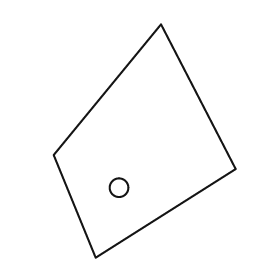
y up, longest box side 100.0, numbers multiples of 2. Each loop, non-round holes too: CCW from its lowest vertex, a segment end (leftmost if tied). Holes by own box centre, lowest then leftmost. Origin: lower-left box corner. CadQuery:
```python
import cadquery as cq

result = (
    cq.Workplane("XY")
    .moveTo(18.0, 0.0)
    .lineTo(78.0, 38.0)
    .lineTo(46.0, 100.0)
    .lineTo(0.0, 44.0)
    .close()
    .moveTo(28.0, 30.0)
    .circle(4.0)
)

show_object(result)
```